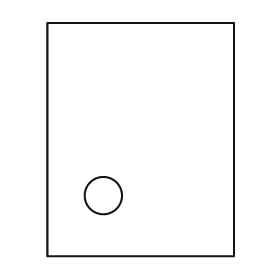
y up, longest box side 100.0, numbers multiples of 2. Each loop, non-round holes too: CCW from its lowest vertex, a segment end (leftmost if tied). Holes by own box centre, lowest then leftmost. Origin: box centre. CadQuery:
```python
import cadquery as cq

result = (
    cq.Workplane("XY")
    .moveTo(-40.0, -50.0)
    .lineTo(40.0, -50.0)
    .lineTo(40.0, 50.0)
    .lineTo(-40.0, 50.0)
    .close()
    .moveTo(-16.0, -24.0)
    .circle(8.0)
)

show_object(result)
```